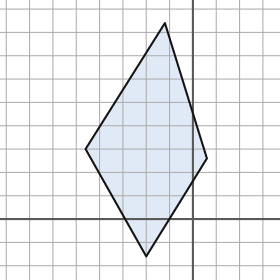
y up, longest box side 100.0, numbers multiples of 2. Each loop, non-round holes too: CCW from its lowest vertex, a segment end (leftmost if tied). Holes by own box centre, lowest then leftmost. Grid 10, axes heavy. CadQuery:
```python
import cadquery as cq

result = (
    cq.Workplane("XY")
    .moveTo(-20.0, -16.0)
    .lineTo(6.0, 26.0)
    .lineTo(-12.0, 84.0)
    .lineTo(-46.0, 30.0)
    .close()
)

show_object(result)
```